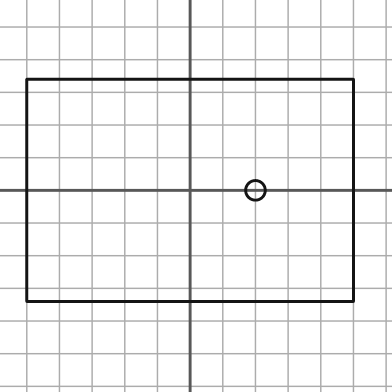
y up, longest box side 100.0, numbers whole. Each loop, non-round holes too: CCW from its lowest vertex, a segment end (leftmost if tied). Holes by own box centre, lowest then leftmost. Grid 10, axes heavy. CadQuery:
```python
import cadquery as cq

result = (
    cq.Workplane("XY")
    .moveTo(-50.0, -34.0)
    .lineTo(50.0, -34.0)
    .lineTo(50.0, 34.0)
    .lineTo(-50.0, 34.0)
    .close()
    .moveTo(20.0, 0.0)
    .circle(3.0)
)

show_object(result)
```